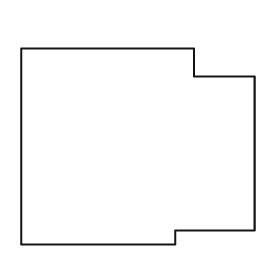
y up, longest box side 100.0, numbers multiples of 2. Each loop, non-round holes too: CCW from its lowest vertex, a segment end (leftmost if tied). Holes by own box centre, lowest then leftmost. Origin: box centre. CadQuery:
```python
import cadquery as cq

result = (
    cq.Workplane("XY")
    .moveTo(-50.0, -42.0)
    .lineTo(16.0, -42.0)
    .lineTo(16.0, -36.0)
    .lineTo(50.0, -36.0)
    .lineTo(50.0, 30.0)
    .lineTo(24.0, 30.0)
    .lineTo(24.0, 42.0)
    .lineTo(-50.0, 42.0)
    .close()
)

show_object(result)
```